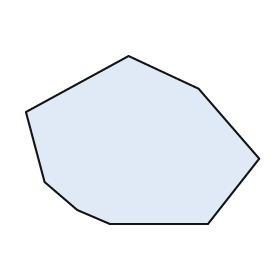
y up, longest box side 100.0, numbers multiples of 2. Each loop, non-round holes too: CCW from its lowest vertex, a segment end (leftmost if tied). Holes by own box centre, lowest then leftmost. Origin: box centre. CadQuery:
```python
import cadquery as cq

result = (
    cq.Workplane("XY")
    .moveTo(-14.0, -36.0)
    .lineTo(28.0, -36.0)
    .lineTo(50.0, -8.0)
    .lineTo(24.0, 22.0)
    .lineTo(-6.0, 36.0)
    .lineTo(-50.0, 12.0)
    .lineTo(-42.0, -18.0)
    .lineTo(-28.0, -30.0)
    .close()
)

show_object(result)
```